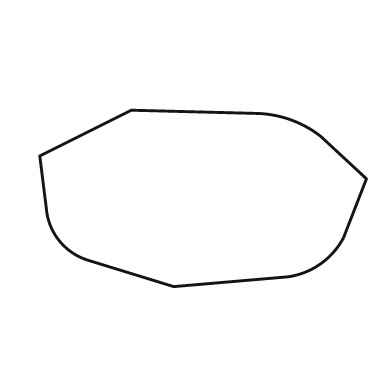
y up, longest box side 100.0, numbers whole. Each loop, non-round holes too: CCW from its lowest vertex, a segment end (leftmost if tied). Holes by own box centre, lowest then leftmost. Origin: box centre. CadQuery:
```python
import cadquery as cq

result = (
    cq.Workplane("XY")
    .moveTo(-9.0, -27.0)
    .lineTo(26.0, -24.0)
    .threePointArc((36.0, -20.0), (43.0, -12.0))
    .lineTo(50.0, 6.0)
    .lineTo(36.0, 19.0)
    .threePointArc((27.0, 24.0), (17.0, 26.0))
    .lineTo(-22.0, 27.0)
    .lineTo(-50.0, 13.0)
    .lineTo(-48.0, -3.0)
    .threePointArc((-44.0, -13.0), (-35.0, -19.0))
    .close()
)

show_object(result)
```